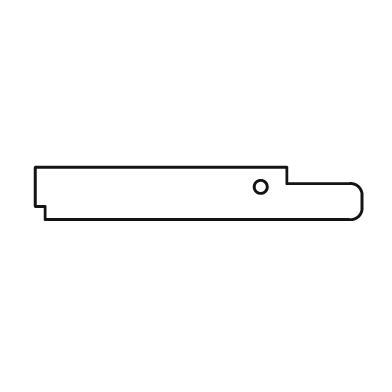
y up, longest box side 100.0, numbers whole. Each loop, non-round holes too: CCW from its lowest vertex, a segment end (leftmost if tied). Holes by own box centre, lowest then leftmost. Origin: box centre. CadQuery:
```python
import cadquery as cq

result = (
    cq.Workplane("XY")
    .moveTo(-47.0, -8.0)
    .lineTo(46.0, -8.0)
    .threePointArc((49.0, -7.0), (50.0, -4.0))
    .lineTo(50.0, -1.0)
    .threePointArc((49.0, 2.0), (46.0, 3.0))
    .lineTo(27.0, 3.0)
    .lineTo(27.0, 8.0)
    .lineTo(-50.0, 8.0)
    .lineTo(-50.0, -4.0)
    .lineTo(-47.0, -4.0)
    .close()
    .moveTo(19.0, 2.0)
    .circle(2.0)
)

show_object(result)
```